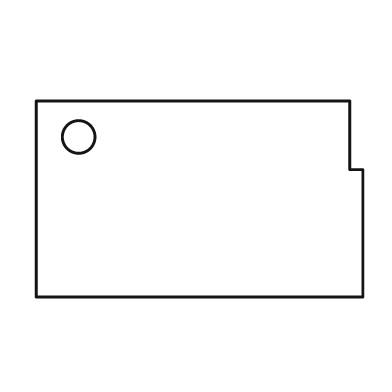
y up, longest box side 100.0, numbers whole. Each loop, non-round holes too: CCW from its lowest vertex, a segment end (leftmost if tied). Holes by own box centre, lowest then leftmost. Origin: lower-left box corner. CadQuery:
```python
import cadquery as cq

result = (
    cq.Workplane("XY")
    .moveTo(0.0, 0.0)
    .lineTo(100.0, 0.0)
    .lineTo(100.0, 39.0)
    .lineTo(96.0, 39.0)
    .lineTo(96.0, 60.0)
    .lineTo(0.0, 60.0)
    .close()
    .moveTo(13.0, 49.0)
    .circle(5.0)
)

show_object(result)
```